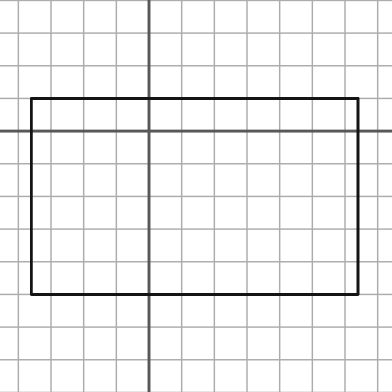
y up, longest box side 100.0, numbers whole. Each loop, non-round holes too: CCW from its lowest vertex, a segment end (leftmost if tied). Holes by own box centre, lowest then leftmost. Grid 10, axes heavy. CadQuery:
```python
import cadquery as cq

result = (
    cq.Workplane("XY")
    .moveTo(-36.0, -50.0)
    .lineTo(64.0, -50.0)
    .lineTo(64.0, 10.0)
    .lineTo(-36.0, 10.0)
    .close()
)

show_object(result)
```